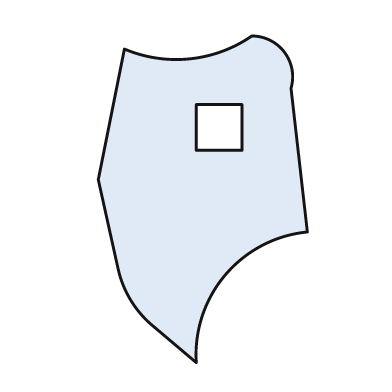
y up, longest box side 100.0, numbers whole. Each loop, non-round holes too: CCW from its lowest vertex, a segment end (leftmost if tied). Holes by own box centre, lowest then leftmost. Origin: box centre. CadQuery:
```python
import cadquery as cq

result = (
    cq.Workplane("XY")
    .moveTo(-2.0, -50.0)
    .threePointArc((7.0, -23.0), (32.0, -10.0))
    .lineTo(27.0, 34.0)
    .threePointArc((25.0, 45.0), (15.0, 50.0))
    .threePointArc((-4.0, 43.0), (-24.0, 46.0))
    .lineTo(-32.0, 6.0)
    .lineTo(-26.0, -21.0)
    .threePointArc((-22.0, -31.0), (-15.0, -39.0))
    .close()
    .moveTo(-2.0, 15.0)
    .lineTo(12.0, 15.0)
    .lineTo(12.0, 29.0)
    .lineTo(-2.0, 29.0)
    .close()
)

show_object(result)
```